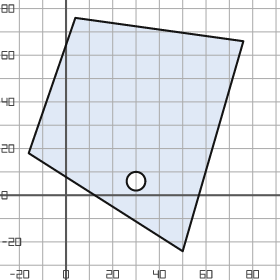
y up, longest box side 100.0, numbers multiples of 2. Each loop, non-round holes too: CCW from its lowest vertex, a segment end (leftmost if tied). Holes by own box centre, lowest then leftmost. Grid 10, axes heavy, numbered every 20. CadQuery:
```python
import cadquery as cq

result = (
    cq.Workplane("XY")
    .moveTo(50.0, -24.0)
    .lineTo(76.0, 66.0)
    .lineTo(4.0, 76.0)
    .lineTo(-16.0, 18.0)
    .close()
    .moveTo(30.0, 6.0)
    .circle(4.0)
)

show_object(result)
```